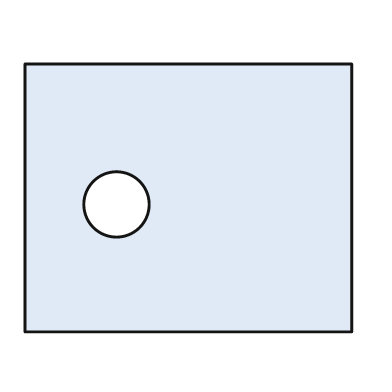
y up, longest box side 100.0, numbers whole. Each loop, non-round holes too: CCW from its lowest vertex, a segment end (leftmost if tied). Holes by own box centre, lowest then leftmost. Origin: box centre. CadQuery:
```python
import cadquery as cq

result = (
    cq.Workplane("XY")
    .moveTo(-50.0, -41.0)
    .lineTo(50.0, -41.0)
    .lineTo(50.0, 41.0)
    .lineTo(-50.0, 41.0)
    .close()
    .moveTo(-22.0, -2.0)
    .circle(10.0)
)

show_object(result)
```